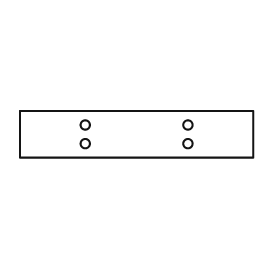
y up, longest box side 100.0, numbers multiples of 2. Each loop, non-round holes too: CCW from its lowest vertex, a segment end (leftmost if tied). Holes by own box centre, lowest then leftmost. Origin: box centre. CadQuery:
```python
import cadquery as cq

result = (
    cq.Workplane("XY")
    .moveTo(-50.0, -10.0)
    .lineTo(50.0, -10.0)
    .lineTo(50.0, 10.0)
    .lineTo(-50.0, 10.0)
    .close()
    .moveTo(-22.0, -4.0)
    .circle(2.0)
    .moveTo(22.0, -4.0)
    .circle(2.0)
    .moveTo(-22.0, 4.0)
    .circle(2.0)
    .moveTo(22.0, 4.0)
    .circle(2.0)
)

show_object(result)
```